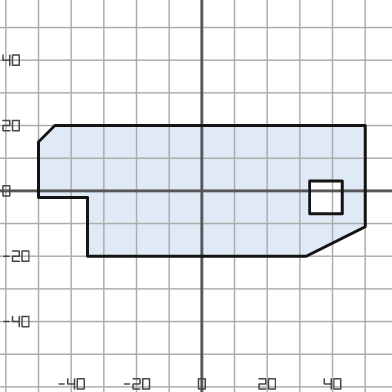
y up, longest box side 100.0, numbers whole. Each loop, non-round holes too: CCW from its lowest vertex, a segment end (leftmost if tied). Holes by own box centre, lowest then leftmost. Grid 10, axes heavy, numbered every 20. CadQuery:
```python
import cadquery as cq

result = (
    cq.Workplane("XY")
    .moveTo(-35.0, -20.0)
    .lineTo(32.0, -20.0)
    .lineTo(50.0, -11.0)
    .lineTo(50.0, 20.0)
    .lineTo(-45.0, 20.0)
    .lineTo(-50.0, 15.0)
    .lineTo(-50.0, -2.0)
    .lineTo(-35.0, -2.0)
    .close()
    .moveTo(33.0, -7.0)
    .lineTo(43.0, -7.0)
    .lineTo(43.0, 3.0)
    .lineTo(33.0, 3.0)
    .close()
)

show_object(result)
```